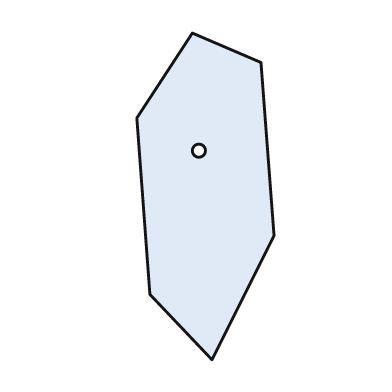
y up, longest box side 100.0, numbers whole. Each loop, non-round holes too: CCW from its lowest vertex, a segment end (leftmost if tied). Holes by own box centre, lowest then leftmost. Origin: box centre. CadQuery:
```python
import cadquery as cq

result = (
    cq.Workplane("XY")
    .moveTo(2.0, -50.0)
    .lineTo(21.0, -12.0)
    .lineTo(17.0, 41.0)
    .lineTo(-4.0, 50.0)
    .lineTo(-21.0, 24.0)
    .lineTo(-17.0, -30.0)
    .close()
    .moveTo(-2.0, 14.0)
    .circle(2.0)
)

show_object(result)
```